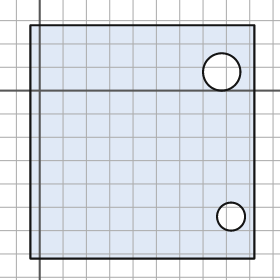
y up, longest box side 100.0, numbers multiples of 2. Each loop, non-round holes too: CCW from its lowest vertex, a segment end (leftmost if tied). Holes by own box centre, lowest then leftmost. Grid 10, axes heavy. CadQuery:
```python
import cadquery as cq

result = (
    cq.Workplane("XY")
    .moveTo(-4.0, -72.0)
    .lineTo(92.0, -72.0)
    .lineTo(92.0, 28.0)
    .lineTo(-4.0, 28.0)
    .close()
    .moveTo(82.0, -54.0)
    .circle(6.0)
    .moveTo(78.0, 8.0)
    .circle(8.0)
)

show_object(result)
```